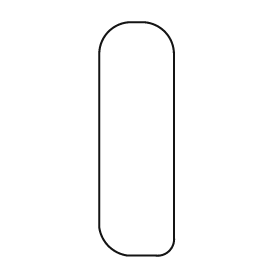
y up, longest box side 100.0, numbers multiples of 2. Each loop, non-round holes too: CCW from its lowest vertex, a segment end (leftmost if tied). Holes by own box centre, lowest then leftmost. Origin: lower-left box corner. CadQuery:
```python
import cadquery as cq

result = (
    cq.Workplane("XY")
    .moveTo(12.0, 0.0)
    .lineTo(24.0, 0.0)
    .threePointArc((30.0, 2.0), (32.0, 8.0))
    .lineTo(32.0, 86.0)
    .threePointArc((28.0, 96.0), (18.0, 100.0))
    .lineTo(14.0, 100.0)
    .threePointArc((4.0, 96.0), (0.0, 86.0))
    .lineTo(0.0, 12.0)
    .threePointArc((4.0, 4.0), (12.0, 0.0))
    .close()
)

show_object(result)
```